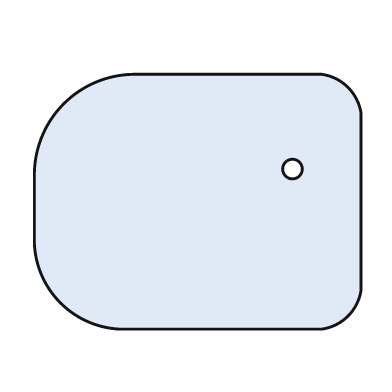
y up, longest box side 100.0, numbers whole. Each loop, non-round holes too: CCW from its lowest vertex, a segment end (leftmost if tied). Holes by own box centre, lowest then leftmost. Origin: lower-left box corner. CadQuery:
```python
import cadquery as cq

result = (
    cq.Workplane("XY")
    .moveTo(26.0, 0.0)
    .lineTo(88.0, 0.0)
    .threePointArc((96.0, 4.0), (100.0, 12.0))
    .lineTo(100.0, 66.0)
    .threePointArc((96.0, 74.0), (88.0, 78.0))
    .lineTo(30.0, 78.0)
    .threePointArc((9.0, 69.0), (0.0, 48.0))
    .lineTo(0.0, 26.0)
    .threePointArc((8.0, 8.0), (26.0, 0.0))
    .close()
    .moveTo(79.0, 49.0)
    .circle(3.0)
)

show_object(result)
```